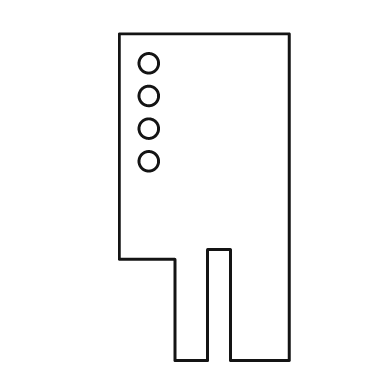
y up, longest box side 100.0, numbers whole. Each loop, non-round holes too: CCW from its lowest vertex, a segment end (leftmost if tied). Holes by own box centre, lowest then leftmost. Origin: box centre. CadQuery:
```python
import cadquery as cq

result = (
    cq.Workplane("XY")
    .moveTo(-9.0, -50.0)
    .lineTo(1.0, -50.0)
    .lineTo(1.0, -16.0)
    .lineTo(8.0, -16.0)
    .lineTo(8.0, -50.0)
    .lineTo(26.0, -50.0)
    .lineTo(26.0, 50.0)
    .lineTo(-26.0, 50.0)
    .lineTo(-26.0, -19.0)
    .lineTo(-9.0, -19.0)
    .close()
    .moveTo(-17.0, 11.0)
    .circle(3.0)
    .moveTo(-17.0, 21.0)
    .circle(3.0)
    .moveTo(-17.0, 31.0)
    .circle(3.0)
    .moveTo(-17.0, 41.0)
    .circle(3.0)
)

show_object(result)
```